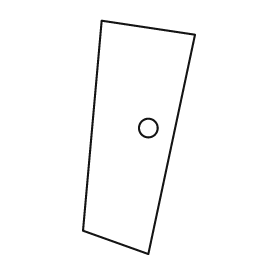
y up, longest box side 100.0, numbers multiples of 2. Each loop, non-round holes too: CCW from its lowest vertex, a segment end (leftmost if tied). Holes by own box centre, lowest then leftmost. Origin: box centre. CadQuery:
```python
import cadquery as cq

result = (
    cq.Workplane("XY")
    .moveTo(4.0, -50.0)
    .lineTo(24.0, 44.0)
    .lineTo(-16.0, 50.0)
    .lineTo(-24.0, -40.0)
    .close()
    .moveTo(4.0, 4.0)
    .circle(4.0)
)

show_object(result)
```